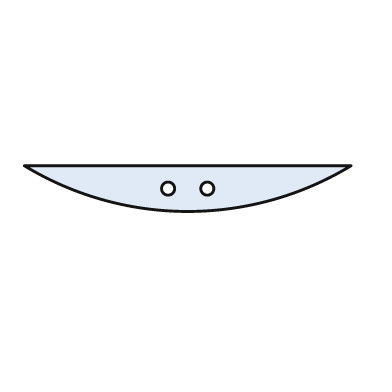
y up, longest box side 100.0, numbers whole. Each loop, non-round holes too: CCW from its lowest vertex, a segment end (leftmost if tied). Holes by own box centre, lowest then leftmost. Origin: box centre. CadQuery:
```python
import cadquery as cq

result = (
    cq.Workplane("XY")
    .moveTo(-50.0, 7.0)
    .threePointArc((0.0, -7.0), (50.0, 7.0))
    .close()
    .moveTo(-6.0, 0.0)
    .circle(2.0)
    .moveTo(6.0, 0.0)
    .circle(2.0)
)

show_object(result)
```